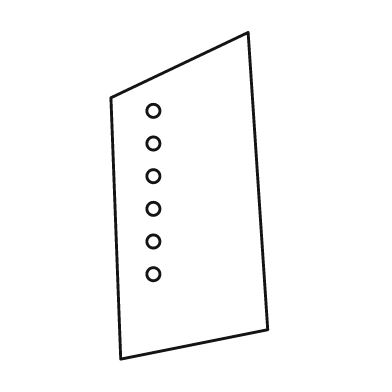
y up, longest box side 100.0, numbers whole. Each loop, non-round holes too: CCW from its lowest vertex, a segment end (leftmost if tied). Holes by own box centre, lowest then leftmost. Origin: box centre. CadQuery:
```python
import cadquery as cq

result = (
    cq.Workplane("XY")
    .moveTo(-21.0, -50.0)
    .lineTo(24.0, -41.0)
    .lineTo(18.0, 50.0)
    .lineTo(-24.0, 30.0)
    .close()
    .moveTo(-11.0, -24.0)
    .circle(2.0)
    .moveTo(-11.0, -14.0)
    .circle(2.0)
    .moveTo(-11.0, -4.0)
    .circle(2.0)
    .moveTo(-11.0, 6.0)
    .circle(2.0)
    .moveTo(-11.0, 16.0)
    .circle(2.0)
    .moveTo(-11.0, 26.0)
    .circle(2.0)
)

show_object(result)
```